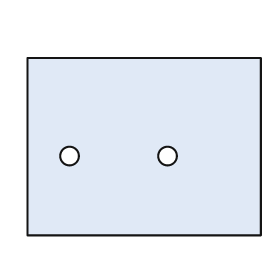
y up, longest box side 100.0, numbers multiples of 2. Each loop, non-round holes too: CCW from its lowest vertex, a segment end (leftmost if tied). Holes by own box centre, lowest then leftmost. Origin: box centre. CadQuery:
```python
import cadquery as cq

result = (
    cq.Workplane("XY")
    .moveTo(-50.0, -38.0)
    .lineTo(50.0, -38.0)
    .lineTo(50.0, 38.0)
    .lineTo(-50.0, 38.0)
    .close()
    .moveTo(-32.0, -4.0)
    .circle(4.0)
    .moveTo(10.0, -4.0)
    .circle(4.0)
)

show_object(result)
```